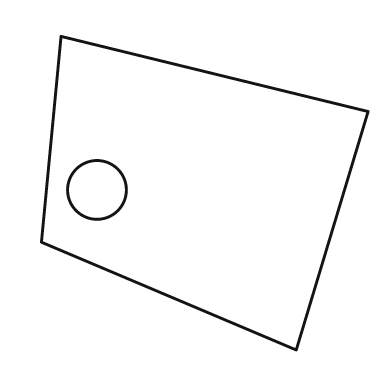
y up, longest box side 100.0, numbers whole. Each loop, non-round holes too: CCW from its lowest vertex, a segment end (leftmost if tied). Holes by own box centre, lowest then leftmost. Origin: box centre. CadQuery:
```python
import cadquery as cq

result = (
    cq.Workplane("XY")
    .moveTo(28.0, -48.0)
    .lineTo(50.0, 25.0)
    .lineTo(-44.0, 48.0)
    .lineTo(-50.0, -15.0)
    .close()
    .moveTo(-33.0, 1.0)
    .circle(9.0)
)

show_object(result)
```